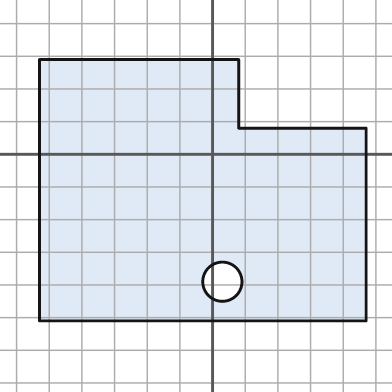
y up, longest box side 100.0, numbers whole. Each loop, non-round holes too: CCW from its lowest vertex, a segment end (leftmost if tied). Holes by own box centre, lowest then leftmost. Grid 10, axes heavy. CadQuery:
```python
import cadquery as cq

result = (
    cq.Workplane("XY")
    .moveTo(-53.0, -51.0)
    .lineTo(47.0, -51.0)
    .lineTo(47.0, 8.0)
    .lineTo(8.0, 8.0)
    .lineTo(8.0, 29.0)
    .lineTo(-53.0, 29.0)
    .close()
    .moveTo(3.0, -39.0)
    .circle(6.0)
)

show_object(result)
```